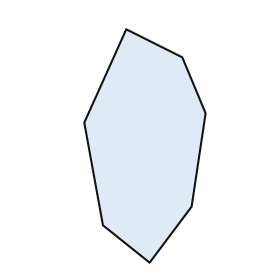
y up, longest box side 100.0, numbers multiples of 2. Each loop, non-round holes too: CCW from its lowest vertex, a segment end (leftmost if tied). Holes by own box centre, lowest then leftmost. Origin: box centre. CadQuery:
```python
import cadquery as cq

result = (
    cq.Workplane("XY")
    .moveTo(2.0, -50.0)
    .lineTo(20.0, -26.0)
    .lineTo(26.0, 14.0)
    .lineTo(16.0, 38.0)
    .lineTo(-8.0, 50.0)
    .lineTo(-26.0, 10.0)
    .lineTo(-18.0, -34.0)
    .close()
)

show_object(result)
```